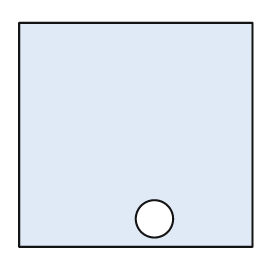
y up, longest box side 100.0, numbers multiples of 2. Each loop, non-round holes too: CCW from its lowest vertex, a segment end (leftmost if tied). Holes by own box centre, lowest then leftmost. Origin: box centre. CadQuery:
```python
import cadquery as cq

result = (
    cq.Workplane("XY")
    .moveTo(-50.0, -48.0)
    .lineTo(50.0, -48.0)
    .lineTo(50.0, 48.0)
    .lineTo(-50.0, 48.0)
    .close()
    .moveTo(8.0, -36.0)
    .circle(8.0)
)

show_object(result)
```